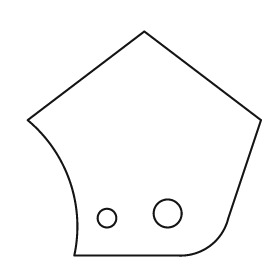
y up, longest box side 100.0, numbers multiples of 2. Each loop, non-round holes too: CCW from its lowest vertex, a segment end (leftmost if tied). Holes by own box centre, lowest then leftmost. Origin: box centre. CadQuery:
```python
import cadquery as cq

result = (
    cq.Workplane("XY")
    .moveTo(-30.0, -48.0)
    .lineTo(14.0, -48.0)
    .threePointArc((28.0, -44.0), (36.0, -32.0))
    .lineTo(50.0, 10.0)
    .lineTo(0.0, 48.0)
    .lineTo(-50.0, 10.0)
    .threePointArc((-32.0, -16.0), (-30.0, -48.0))
    .close()
    .moveTo(-16.0, -32.0)
    .circle(4.0)
    .moveTo(10.0, -30.0)
    .circle(6.0)
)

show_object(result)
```